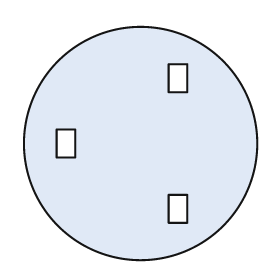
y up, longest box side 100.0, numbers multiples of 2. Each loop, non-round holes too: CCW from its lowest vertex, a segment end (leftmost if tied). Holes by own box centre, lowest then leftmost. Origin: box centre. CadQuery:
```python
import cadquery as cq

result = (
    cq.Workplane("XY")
    .moveTo(0.0, 0.0)
    .circle(50.0)
    .moveTo(12.0, -34.0)
    .lineTo(20.0, -34.0)
    .lineTo(20.0, -22.0)
    .lineTo(12.0, -22.0)
    .close()
    .moveTo(-36.0, -6.0)
    .lineTo(-28.0, -6.0)
    .lineTo(-28.0, 6.0)
    .lineTo(-36.0, 6.0)
    .close()
    .moveTo(12.0, 22.0)
    .lineTo(20.0, 22.0)
    .lineTo(20.0, 34.0)
    .lineTo(12.0, 34.0)
    .close()
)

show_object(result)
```